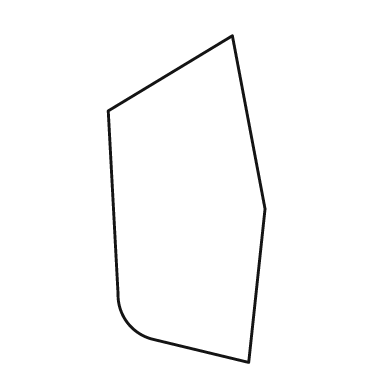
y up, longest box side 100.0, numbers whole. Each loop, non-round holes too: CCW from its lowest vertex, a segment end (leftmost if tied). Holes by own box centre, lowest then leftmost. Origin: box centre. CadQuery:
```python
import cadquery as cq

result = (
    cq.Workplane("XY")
    .moveTo(19.0, -50.0)
    .lineTo(24.0, -3.0)
    .lineTo(14.0, 50.0)
    .lineTo(-24.0, 27.0)
    .lineTo(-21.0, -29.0)
    .threePointArc((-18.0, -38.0), (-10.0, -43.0))
    .close()
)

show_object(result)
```